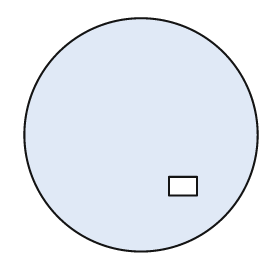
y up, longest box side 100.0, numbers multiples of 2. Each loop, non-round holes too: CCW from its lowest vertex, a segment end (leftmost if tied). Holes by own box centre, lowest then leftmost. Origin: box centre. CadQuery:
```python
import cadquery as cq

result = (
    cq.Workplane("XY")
    .moveTo(0.0, 0.0)
    .circle(50.0)
    .moveTo(12.0, -26.0)
    .lineTo(24.0, -26.0)
    .lineTo(24.0, -18.0)
    .lineTo(12.0, -18.0)
    .close()
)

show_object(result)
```